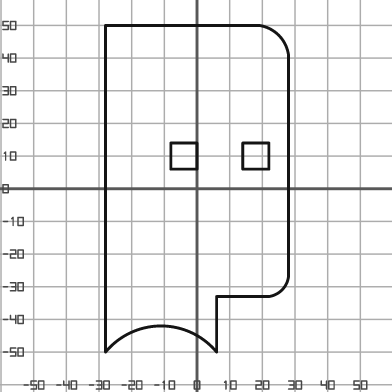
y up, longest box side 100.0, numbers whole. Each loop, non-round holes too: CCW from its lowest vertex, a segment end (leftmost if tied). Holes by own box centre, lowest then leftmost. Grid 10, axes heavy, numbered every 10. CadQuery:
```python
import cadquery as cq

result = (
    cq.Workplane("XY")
    .moveTo(-28.0, -50.0)
    .threePointArc((-11.0, -42.0), (6.0, -50.0))
    .lineTo(6.0, -33.0)
    .lineTo(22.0, -33.0)
    .threePointArc((26.0, -31.0), (28.0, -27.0))
    .lineTo(28.0, 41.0)
    .threePointArc((25.0, 47.0), (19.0, 50.0))
    .lineTo(-28.0, 50.0)
    .close()
    .moveTo(-8.0, 6.0)
    .lineTo(0.0, 6.0)
    .lineTo(0.0, 14.0)
    .lineTo(-8.0, 14.0)
    .close()
    .moveTo(14.0, 6.0)
    .lineTo(22.0, 6.0)
    .lineTo(22.0, 14.0)
    .lineTo(14.0, 14.0)
    .close()
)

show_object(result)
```